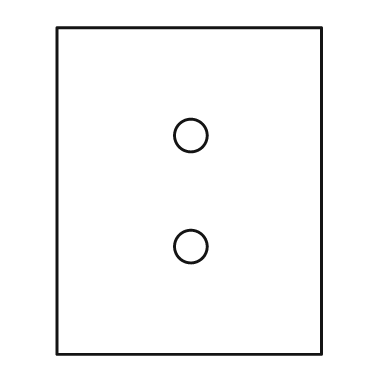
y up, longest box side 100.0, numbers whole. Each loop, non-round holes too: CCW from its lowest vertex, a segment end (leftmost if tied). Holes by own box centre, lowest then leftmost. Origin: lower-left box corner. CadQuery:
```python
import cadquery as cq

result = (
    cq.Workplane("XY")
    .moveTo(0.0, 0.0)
    .lineTo(81.0, 0.0)
    .lineTo(81.0, 100.0)
    .lineTo(0.0, 100.0)
    .close()
    .moveTo(41.0, 33.0)
    .circle(5.0)
    .moveTo(41.0, 67.0)
    .circle(5.0)
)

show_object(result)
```